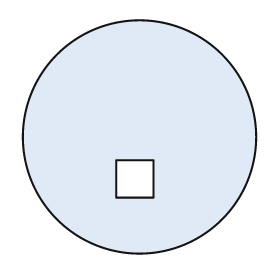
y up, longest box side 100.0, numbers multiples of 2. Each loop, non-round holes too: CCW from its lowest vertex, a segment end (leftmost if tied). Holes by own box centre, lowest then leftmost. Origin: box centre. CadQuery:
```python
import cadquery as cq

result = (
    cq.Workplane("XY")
    .moveTo(0.0, 0.0)
    .circle(50.0)
    .moveTo(-10.0, -26.0)
    .lineTo(6.0, -26.0)
    .lineTo(6.0, -10.0)
    .lineTo(-10.0, -10.0)
    .close()
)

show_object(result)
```